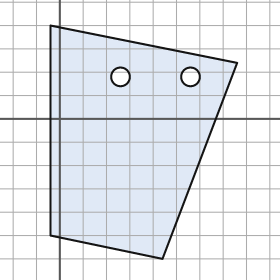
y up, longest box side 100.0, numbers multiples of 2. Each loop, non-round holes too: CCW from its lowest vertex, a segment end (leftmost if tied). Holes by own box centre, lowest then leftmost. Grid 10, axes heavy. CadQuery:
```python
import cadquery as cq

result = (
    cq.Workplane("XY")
    .moveTo(44.0, -60.0)
    .lineTo(76.0, 24.0)
    .lineTo(-4.0, 40.0)
    .lineTo(-4.0, -50.0)
    .close()
    .moveTo(26.0, 18.0)
    .circle(4.0)
    .moveTo(56.0, 18.0)
    .circle(4.0)
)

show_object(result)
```